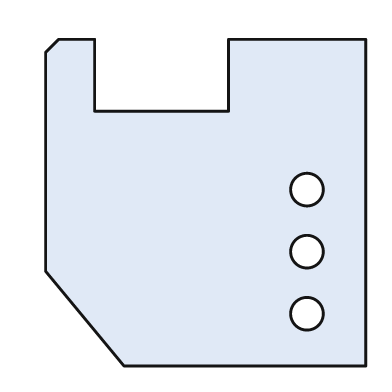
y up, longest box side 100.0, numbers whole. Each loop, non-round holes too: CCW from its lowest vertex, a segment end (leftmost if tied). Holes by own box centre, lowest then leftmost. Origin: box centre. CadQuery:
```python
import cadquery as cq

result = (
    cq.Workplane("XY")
    .moveTo(-25.0, -50.0)
    .lineTo(49.0, -50.0)
    .lineTo(49.0, 50.0)
    .lineTo(7.0, 50.0)
    .lineTo(7.0, 28.0)
    .lineTo(-34.0, 28.0)
    .lineTo(-34.0, 50.0)
    .lineTo(-45.0, 50.0)
    .lineTo(-49.0, 46.0)
    .lineTo(-49.0, -21.0)
    .close()
    .moveTo(31.0, -34.0)
    .circle(5.0)
    .moveTo(31.0, -15.0)
    .circle(5.0)
    .moveTo(31.0, 4.0)
    .circle(5.0)
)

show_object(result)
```